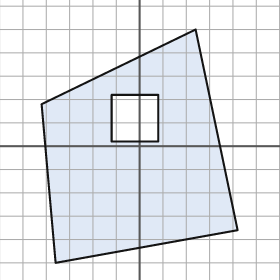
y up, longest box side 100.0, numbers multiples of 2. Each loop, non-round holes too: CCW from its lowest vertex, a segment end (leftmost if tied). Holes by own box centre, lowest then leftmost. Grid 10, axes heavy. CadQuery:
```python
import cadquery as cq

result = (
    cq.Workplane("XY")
    .moveTo(-36.0, -50.0)
    .lineTo(42.0, -36.0)
    .lineTo(24.0, 50.0)
    .lineTo(-42.0, 18.0)
    .close()
    .moveTo(-12.0, 2.0)
    .lineTo(8.0, 2.0)
    .lineTo(8.0, 22.0)
    .lineTo(-12.0, 22.0)
    .close()
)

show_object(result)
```